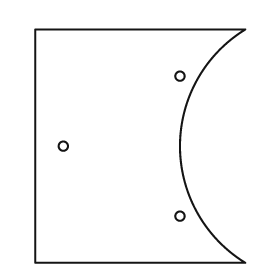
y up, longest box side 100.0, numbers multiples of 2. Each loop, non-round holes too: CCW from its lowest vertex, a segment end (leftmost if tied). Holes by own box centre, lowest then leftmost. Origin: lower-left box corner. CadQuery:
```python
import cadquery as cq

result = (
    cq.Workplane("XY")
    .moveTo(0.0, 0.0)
    .lineTo(90.0, 0.0)
    .threePointArc((62.0, 50.0), (90.0, 100.0))
    .lineTo(0.0, 100.0)
    .close()
    .moveTo(62.0, 20.0)
    .circle(2.0)
    .moveTo(12.0, 50.0)
    .circle(2.0)
    .moveTo(62.0, 80.0)
    .circle(2.0)
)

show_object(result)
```